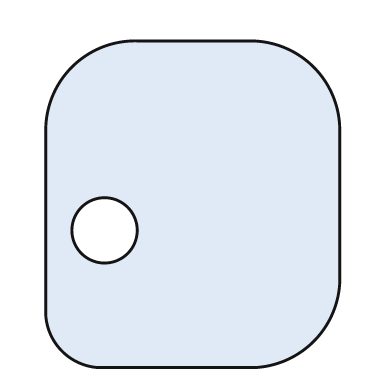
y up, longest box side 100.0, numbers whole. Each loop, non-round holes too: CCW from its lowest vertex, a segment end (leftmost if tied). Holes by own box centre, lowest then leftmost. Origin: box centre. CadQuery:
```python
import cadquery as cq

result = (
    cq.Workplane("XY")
    .moveTo(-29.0, -50.0)
    .lineTo(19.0, -50.0)
    .threePointArc((37.0, -42.0), (45.0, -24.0))
    .lineTo(45.0, 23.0)
    .threePointArc((37.0, 42.0), (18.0, 50.0))
    .lineTo(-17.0, 50.0)
    .threePointArc((-37.0, 42.0), (-45.0, 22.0))
    .lineTo(-45.0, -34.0)
    .threePointArc((-40.0, -45.0), (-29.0, -50.0))
    .close()
    .moveTo(-27.0, -8.0)
    .circle(10.0)
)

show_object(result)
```